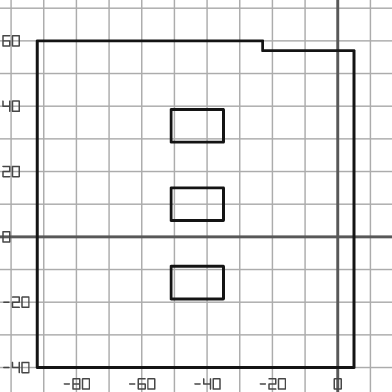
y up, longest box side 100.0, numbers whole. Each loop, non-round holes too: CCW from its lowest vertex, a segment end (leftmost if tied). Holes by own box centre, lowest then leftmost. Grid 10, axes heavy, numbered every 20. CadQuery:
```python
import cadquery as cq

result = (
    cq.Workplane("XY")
    .moveTo(-92.0, -40.0)
    .lineTo(5.0, -40.0)
    .lineTo(5.0, 57.0)
    .lineTo(-23.0, 57.0)
    .lineTo(-23.0, 60.0)
    .lineTo(-92.0, 60.0)
    .close()
    .moveTo(-51.0, -19.0)
    .lineTo(-35.0, -19.0)
    .lineTo(-35.0, -9.0)
    .lineTo(-51.0, -9.0)
    .close()
    .moveTo(-51.0, 5.0)
    .lineTo(-35.0, 5.0)
    .lineTo(-35.0, 15.0)
    .lineTo(-51.0, 15.0)
    .close()
    .moveTo(-51.0, 29.0)
    .lineTo(-35.0, 29.0)
    .lineTo(-35.0, 39.0)
    .lineTo(-51.0, 39.0)
    .close()
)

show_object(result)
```